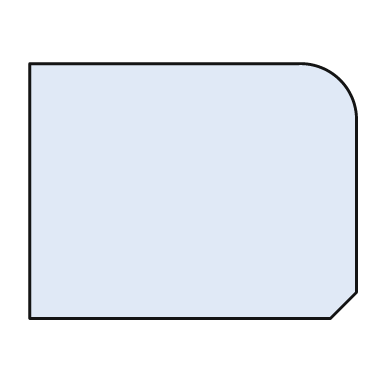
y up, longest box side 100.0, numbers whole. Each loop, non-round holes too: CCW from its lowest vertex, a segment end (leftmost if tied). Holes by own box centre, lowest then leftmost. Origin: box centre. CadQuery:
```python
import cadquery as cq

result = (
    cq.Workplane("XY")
    .moveTo(-50.0, -39.0)
    .lineTo(42.0, -39.0)
    .lineTo(50.0, -31.0)
    .lineTo(50.0, 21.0)
    .threePointArc((45.0, 34.0), (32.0, 39.0))
    .lineTo(-50.0, 39.0)
    .close()
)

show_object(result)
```